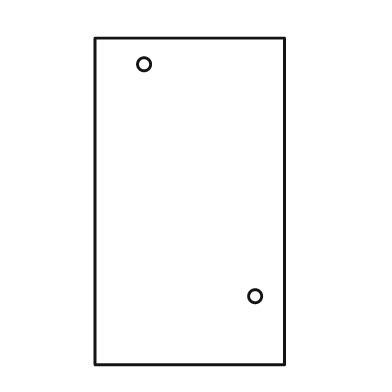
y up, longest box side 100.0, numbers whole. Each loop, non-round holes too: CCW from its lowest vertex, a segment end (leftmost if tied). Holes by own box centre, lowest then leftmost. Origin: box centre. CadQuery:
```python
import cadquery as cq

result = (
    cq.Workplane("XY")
    .moveTo(-29.0, -50.0)
    .lineTo(29.0, -50.0)
    .lineTo(29.0, 50.0)
    .lineTo(-29.0, 50.0)
    .close()
    .moveTo(20.0, -29.0)
    .circle(2.0)
    .moveTo(-14.0, 42.0)
    .circle(2.0)
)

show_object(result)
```